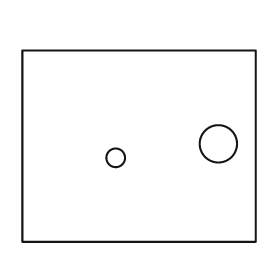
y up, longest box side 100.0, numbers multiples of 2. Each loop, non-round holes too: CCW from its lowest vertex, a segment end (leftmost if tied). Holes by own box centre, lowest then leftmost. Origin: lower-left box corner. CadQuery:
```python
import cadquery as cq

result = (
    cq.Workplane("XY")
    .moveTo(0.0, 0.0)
    .lineTo(100.0, 0.0)
    .lineTo(100.0, 82.0)
    .lineTo(0.0, 82.0)
    .close()
    .moveTo(40.0, 36.0)
    .circle(4.0)
    .moveTo(84.0, 42.0)
    .circle(8.0)
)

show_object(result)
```